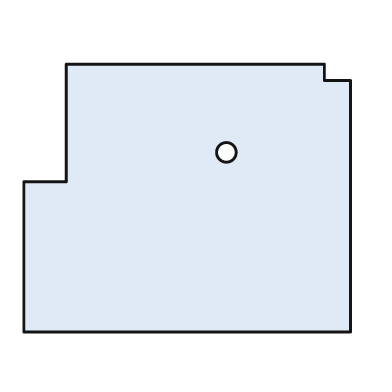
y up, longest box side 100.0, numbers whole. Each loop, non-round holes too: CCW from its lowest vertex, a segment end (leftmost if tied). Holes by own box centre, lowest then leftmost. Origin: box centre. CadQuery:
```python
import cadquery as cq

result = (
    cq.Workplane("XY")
    .moveTo(-50.0, -41.0)
    .lineTo(50.0, -41.0)
    .lineTo(50.0, 36.0)
    .lineTo(42.0, 36.0)
    .lineTo(42.0, 41.0)
    .lineTo(-37.0, 41.0)
    .lineTo(-37.0, 5.0)
    .lineTo(-50.0, 5.0)
    .close()
    .moveTo(12.0, 14.0)
    .circle(3.0)
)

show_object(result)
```